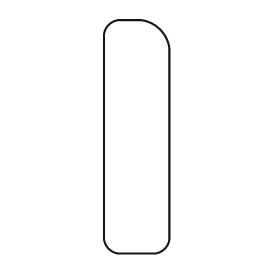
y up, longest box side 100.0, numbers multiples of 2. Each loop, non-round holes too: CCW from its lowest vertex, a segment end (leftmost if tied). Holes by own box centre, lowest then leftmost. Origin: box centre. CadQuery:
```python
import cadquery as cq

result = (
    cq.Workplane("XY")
    .moveTo(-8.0, -50.0)
    .lineTo(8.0, -50.0)
    .threePointArc((12.0, -48.0), (14.0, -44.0))
    .lineTo(14.0, 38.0)
    .threePointArc((10.0, 46.0), (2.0, 50.0))
    .lineTo(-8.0, 50.0)
    .threePointArc((-12.0, 48.0), (-14.0, 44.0))
    .lineTo(-14.0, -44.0)
    .threePointArc((-12.0, -48.0), (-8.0, -50.0))
    .close()
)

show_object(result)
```